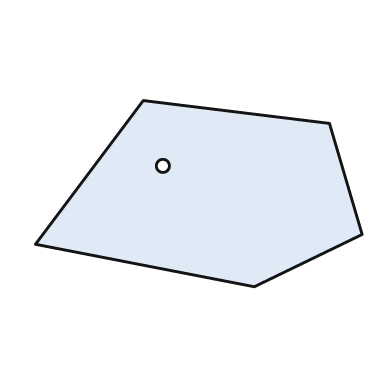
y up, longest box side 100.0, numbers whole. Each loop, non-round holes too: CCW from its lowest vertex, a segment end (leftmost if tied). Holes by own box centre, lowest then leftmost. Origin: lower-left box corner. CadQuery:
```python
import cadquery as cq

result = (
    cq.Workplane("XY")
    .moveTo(67.0, 0.0)
    .lineTo(100.0, 16.0)
    .lineTo(90.0, 50.0)
    .lineTo(33.0, 57.0)
    .lineTo(0.0, 13.0)
    .close()
    .moveTo(39.0, 37.0)
    .circle(2.0)
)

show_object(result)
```